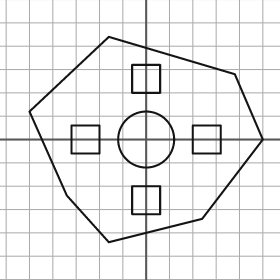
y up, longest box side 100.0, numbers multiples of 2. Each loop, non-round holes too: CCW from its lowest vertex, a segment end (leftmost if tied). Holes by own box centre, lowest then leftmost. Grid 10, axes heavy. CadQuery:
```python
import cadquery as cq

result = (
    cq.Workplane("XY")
    .moveTo(-16.0, -44.0)
    .lineTo(24.0, -34.0)
    .lineTo(50.0, 0.0)
    .lineTo(38.0, 28.0)
    .lineTo(-16.0, 44.0)
    .lineTo(-50.0, 12.0)
    .lineTo(-34.0, -24.0)
    .close()
    .moveTo(-6.0, -32.0)
    .lineTo(6.0, -32.0)
    .lineTo(6.0, -20.0)
    .lineTo(-6.0, -20.0)
    .close()
    .moveTo(-32.0, -6.0)
    .lineTo(-20.0, -6.0)
    .lineTo(-20.0, 6.0)
    .lineTo(-32.0, 6.0)
    .close()
    .moveTo(0.0, 0.0)
    .circle(12.0)
    .moveTo(20.0, -6.0)
    .lineTo(32.0, -6.0)
    .lineTo(32.0, 6.0)
    .lineTo(20.0, 6.0)
    .close()
    .moveTo(-6.0, 20.0)
    .lineTo(6.0, 20.0)
    .lineTo(6.0, 32.0)
    .lineTo(-6.0, 32.0)
    .close()
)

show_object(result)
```